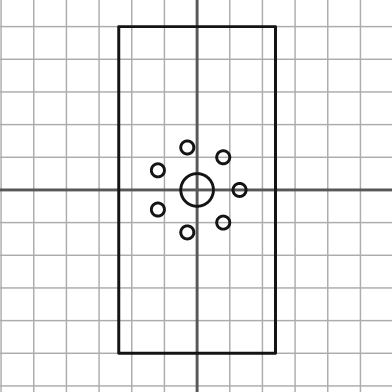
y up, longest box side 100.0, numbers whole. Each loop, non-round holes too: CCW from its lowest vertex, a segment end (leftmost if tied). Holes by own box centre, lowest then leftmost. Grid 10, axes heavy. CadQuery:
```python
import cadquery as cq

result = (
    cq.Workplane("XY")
    .moveTo(-24.0, -50.0)
    .lineTo(24.0, -50.0)
    .lineTo(24.0, 50.0)
    .lineTo(-24.0, 50.0)
    .close()
    .moveTo(-3.0, -13.0)
    .circle(2.0)
    .moveTo(8.0, -10.0)
    .circle(2.0)
    .moveTo(-12.0, -6.0)
    .circle(2.0)
    .moveTo(0.0, 0.0)
    .circle(5.0)
    .moveTo(13.0, 0.0)
    .circle(2.0)
    .moveTo(-12.0, 6.0)
    .circle(2.0)
    .moveTo(8.0, 10.0)
    .circle(2.0)
    .moveTo(-3.0, 13.0)
    .circle(2.0)
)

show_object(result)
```